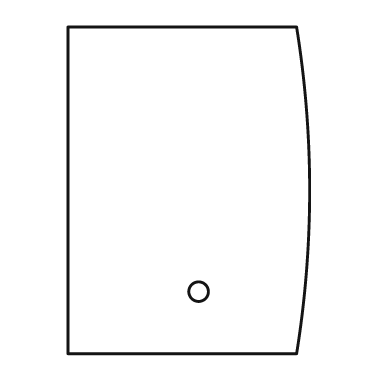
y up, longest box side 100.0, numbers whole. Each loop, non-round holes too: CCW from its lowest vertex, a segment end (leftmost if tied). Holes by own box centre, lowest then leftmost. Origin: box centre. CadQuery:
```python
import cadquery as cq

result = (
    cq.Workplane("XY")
    .moveTo(-37.0, -50.0)
    .lineTo(33.0, -50.0)
    .threePointArc((37.0, 0.0), (33.0, 50.0))
    .lineTo(-37.0, 50.0)
    .close()
    .moveTo(3.0, -31.0)
    .circle(3.0)
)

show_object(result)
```